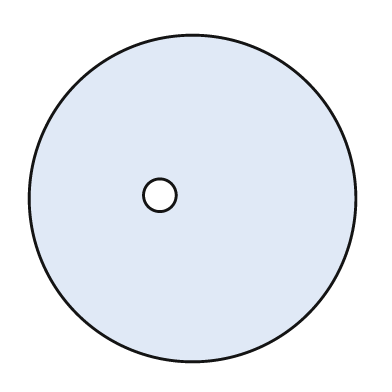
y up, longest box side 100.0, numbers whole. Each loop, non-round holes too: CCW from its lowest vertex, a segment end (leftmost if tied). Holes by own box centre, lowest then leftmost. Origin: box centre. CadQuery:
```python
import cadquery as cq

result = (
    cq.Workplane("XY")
    .moveTo(0.0, 0.0)
    .circle(50.0)
    .moveTo(-10.0, 1.0)
    .circle(5.0)
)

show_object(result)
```